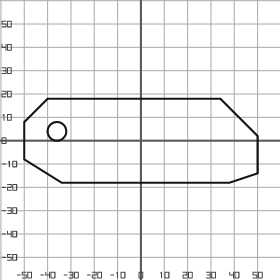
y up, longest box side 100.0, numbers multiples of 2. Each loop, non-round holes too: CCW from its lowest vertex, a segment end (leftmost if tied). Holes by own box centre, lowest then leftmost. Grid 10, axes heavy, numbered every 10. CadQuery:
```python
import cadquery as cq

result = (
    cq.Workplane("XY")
    .moveTo(-34.0, -18.0)
    .lineTo(38.0, -18.0)
    .lineTo(50.0, -14.0)
    .lineTo(50.0, 2.0)
    .lineTo(34.0, 18.0)
    .lineTo(-40.0, 18.0)
    .lineTo(-50.0, 8.0)
    .lineTo(-50.0, -8.0)
    .close()
    .moveTo(-36.0, 4.0)
    .circle(4.0)
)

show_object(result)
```